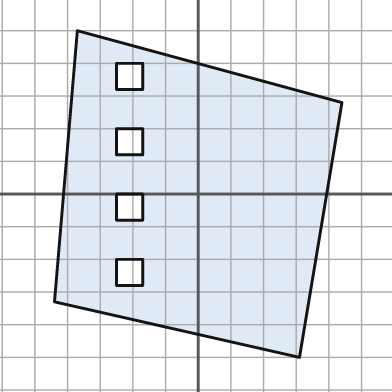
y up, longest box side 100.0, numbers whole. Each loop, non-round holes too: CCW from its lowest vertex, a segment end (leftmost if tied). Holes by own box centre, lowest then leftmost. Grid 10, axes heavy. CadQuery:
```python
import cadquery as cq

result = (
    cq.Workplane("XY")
    .moveTo(31.0, -50.0)
    .lineTo(44.0, 28.0)
    .lineTo(-37.0, 50.0)
    .lineTo(-44.0, -33.0)
    .close()
    .moveTo(-25.0, -28.0)
    .lineTo(-17.0, -28.0)
    .lineTo(-17.0, -20.0)
    .lineTo(-25.0, -20.0)
    .close()
    .moveTo(-25.0, -8.0)
    .lineTo(-17.0, -8.0)
    .lineTo(-17.0, 0.0)
    .lineTo(-25.0, 0.0)
    .close()
    .moveTo(-25.0, 12.0)
    .lineTo(-17.0, 12.0)
    .lineTo(-17.0, 20.0)
    .lineTo(-25.0, 20.0)
    .close()
    .moveTo(-25.0, 32.0)
    .lineTo(-17.0, 32.0)
    .lineTo(-17.0, 40.0)
    .lineTo(-25.0, 40.0)
    .close()
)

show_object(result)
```